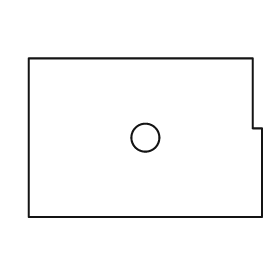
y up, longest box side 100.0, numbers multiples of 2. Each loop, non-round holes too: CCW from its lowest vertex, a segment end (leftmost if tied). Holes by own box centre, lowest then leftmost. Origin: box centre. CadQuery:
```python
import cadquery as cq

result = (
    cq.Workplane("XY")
    .moveTo(-50.0, -34.0)
    .lineTo(50.0, -34.0)
    .lineTo(50.0, 4.0)
    .lineTo(46.0, 4.0)
    .lineTo(46.0, 34.0)
    .lineTo(-50.0, 34.0)
    .close()
    .moveTo(0.0, 0.0)
    .circle(6.0)
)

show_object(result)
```